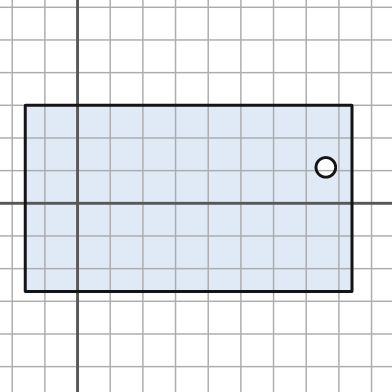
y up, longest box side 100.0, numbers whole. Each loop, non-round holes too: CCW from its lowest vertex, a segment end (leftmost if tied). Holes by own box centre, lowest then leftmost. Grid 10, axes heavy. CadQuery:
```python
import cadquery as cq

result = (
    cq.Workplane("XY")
    .moveTo(-16.0, -27.0)
    .lineTo(84.0, -27.0)
    .lineTo(84.0, 30.0)
    .lineTo(-16.0, 30.0)
    .close()
    .moveTo(76.0, 11.0)
    .circle(3.0)
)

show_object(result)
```